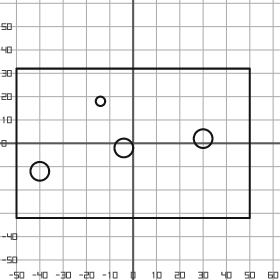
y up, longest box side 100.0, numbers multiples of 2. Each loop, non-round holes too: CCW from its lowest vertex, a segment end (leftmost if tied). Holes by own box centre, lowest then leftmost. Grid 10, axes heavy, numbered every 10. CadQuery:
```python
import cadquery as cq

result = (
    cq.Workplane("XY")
    .moveTo(-50.0, -32.0)
    .lineTo(50.0, -32.0)
    .lineTo(50.0, 32.0)
    .lineTo(-50.0, 32.0)
    .close()
    .moveTo(-40.0, -12.0)
    .circle(4.0)
    .moveTo(-4.0, -2.0)
    .circle(4.0)
    .moveTo(30.0, 2.0)
    .circle(4.0)
    .moveTo(-14.0, 18.0)
    .circle(2.0)
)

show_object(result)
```